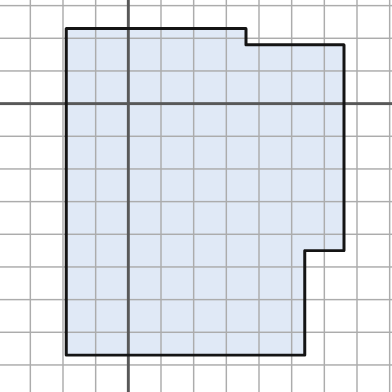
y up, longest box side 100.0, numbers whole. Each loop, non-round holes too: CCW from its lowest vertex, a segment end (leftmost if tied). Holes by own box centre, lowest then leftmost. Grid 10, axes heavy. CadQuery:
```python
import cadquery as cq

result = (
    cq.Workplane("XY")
    .moveTo(-19.0, -77.0)
    .lineTo(54.0, -77.0)
    .lineTo(54.0, -45.0)
    .lineTo(66.0, -45.0)
    .lineTo(66.0, 18.0)
    .lineTo(36.0, 18.0)
    .lineTo(36.0, 23.0)
    .lineTo(-19.0, 23.0)
    .close()
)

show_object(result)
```